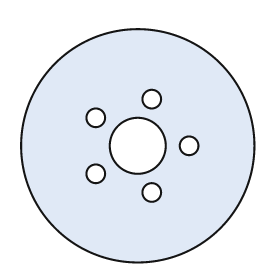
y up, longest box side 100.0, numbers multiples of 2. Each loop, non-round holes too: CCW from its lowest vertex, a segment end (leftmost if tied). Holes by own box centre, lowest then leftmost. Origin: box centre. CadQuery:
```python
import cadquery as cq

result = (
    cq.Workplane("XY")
    .moveTo(0.0, 0.0)
    .circle(50.0)
    .moveTo(6.0, -20.0)
    .circle(4.0)
    .moveTo(-18.0, -12.0)
    .circle(4.0)
    .moveTo(0.0, 0.0)
    .circle(12.0)
    .moveTo(22.0, 0.0)
    .circle(4.0)
    .moveTo(-18.0, 12.0)
    .circle(4.0)
    .moveTo(6.0, 20.0)
    .circle(4.0)
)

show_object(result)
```